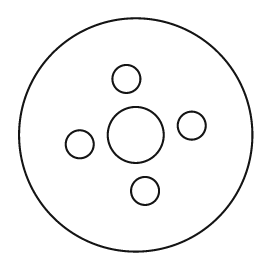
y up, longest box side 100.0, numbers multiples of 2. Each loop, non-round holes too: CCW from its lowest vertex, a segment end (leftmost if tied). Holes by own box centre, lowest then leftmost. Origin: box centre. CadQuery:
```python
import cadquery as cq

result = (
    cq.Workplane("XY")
    .moveTo(0.0, 0.0)
    .circle(50.0)
    .moveTo(4.0, -24.0)
    .circle(6.0)
    .moveTo(-24.0, -4.0)
    .circle(6.0)
    .moveTo(0.0, 0.0)
    .circle(12.0)
    .moveTo(24.0, 4.0)
    .circle(6.0)
    .moveTo(-4.0, 24.0)
    .circle(6.0)
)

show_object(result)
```